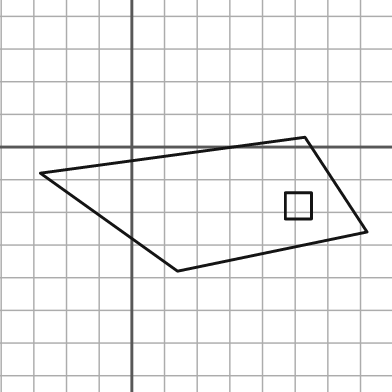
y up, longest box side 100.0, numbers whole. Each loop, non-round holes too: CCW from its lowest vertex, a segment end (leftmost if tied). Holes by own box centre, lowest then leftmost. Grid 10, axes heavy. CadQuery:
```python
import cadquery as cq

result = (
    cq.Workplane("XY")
    .moveTo(14.0, -38.0)
    .lineTo(72.0, -26.0)
    .lineTo(53.0, 3.0)
    .lineTo(-28.0, -8.0)
    .close()
    .moveTo(47.0, -22.0)
    .lineTo(55.0, -22.0)
    .lineTo(55.0, -14.0)
    .lineTo(47.0, -14.0)
    .close()
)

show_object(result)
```